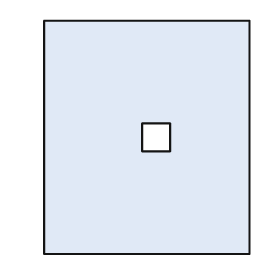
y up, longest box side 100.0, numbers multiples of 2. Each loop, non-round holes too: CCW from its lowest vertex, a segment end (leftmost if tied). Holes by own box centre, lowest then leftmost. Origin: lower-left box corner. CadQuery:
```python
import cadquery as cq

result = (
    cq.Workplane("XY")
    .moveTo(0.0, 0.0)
    .lineTo(88.0, 0.0)
    .lineTo(88.0, 100.0)
    .lineTo(0.0, 100.0)
    .close()
    .moveTo(42.0, 44.0)
    .lineTo(54.0, 44.0)
    .lineTo(54.0, 56.0)
    .lineTo(42.0, 56.0)
    .close()
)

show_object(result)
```